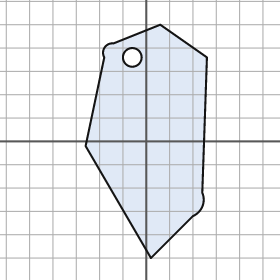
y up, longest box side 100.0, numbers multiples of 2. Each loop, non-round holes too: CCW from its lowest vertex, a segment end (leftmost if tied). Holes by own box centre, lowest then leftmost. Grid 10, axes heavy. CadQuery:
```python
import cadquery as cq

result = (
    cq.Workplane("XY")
    .moveTo(2.0, -50.0)
    .lineTo(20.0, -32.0)
    .threePointArc((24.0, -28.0), (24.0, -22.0))
    .lineTo(26.0, 36.0)
    .lineTo(6.0, 50.0)
    .lineTo(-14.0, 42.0)
    .threePointArc((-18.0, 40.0), (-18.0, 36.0))
    .lineTo(-26.0, -2.0)
    .close()
    .moveTo(-6.0, 36.0)
    .circle(4.0)
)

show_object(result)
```